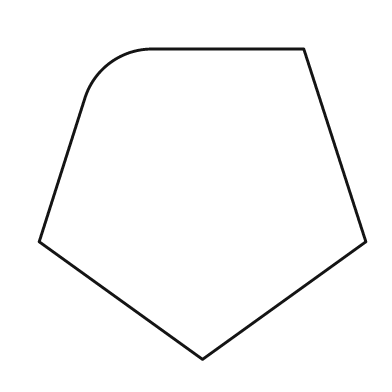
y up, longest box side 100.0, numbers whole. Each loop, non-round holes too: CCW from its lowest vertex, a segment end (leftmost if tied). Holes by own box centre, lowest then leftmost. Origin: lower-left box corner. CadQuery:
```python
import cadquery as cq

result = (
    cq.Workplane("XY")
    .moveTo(50.0, 0.0)
    .lineTo(100.0, 36.0)
    .lineTo(81.0, 95.0)
    .lineTo(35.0, 95.0)
    .threePointArc((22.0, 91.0), (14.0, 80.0))
    .lineTo(0.0, 36.0)
    .close()
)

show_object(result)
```